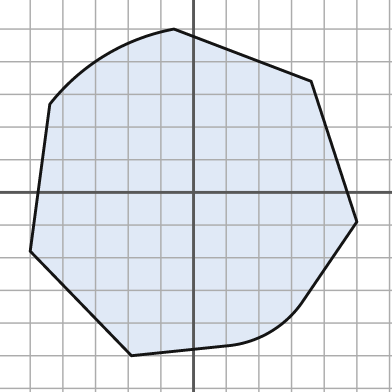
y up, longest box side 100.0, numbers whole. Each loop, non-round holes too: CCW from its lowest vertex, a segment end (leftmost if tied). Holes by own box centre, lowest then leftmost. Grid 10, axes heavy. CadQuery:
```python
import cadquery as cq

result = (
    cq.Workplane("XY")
    .moveTo(-19.0, -50.0)
    .lineTo(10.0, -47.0)
    .threePointArc((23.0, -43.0), (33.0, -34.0))
    .lineTo(50.0, -9.0)
    .lineTo(36.0, 34.0)
    .lineTo(-6.0, 50.0)
    .threePointArc((-27.0, 42.0), (-44.0, 27.0))
    .lineTo(-50.0, -18.0)
    .close()
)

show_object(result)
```